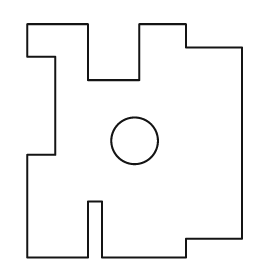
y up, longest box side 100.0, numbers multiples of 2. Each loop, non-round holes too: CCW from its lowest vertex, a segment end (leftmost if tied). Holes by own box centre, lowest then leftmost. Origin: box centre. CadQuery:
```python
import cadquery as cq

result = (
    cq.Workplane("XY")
    .moveTo(-46.0, -50.0)
    .lineTo(-20.0, -50.0)
    .lineTo(-20.0, -26.0)
    .lineTo(-14.0, -26.0)
    .lineTo(-14.0, -50.0)
    .lineTo(22.0, -50.0)
    .lineTo(22.0, -42.0)
    .lineTo(46.0, -42.0)
    .lineTo(46.0, 40.0)
    .lineTo(22.0, 40.0)
    .lineTo(22.0, 50.0)
    .lineTo(2.0, 50.0)
    .lineTo(2.0, 26.0)
    .lineTo(-20.0, 26.0)
    .lineTo(-20.0, 50.0)
    .lineTo(-46.0, 50.0)
    .lineTo(-46.0, 36.0)
    .lineTo(-34.0, 36.0)
    .lineTo(-34.0, -6.0)
    .lineTo(-46.0, -6.0)
    .close()
    .moveTo(0.0, 0.0)
    .circle(10.0)
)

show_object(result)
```